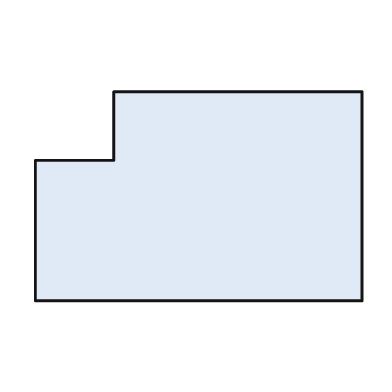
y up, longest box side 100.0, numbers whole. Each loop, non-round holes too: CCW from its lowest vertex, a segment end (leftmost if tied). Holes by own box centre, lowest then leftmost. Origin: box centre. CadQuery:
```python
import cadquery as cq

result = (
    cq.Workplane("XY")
    .moveTo(-50.0, -32.0)
    .lineTo(50.0, -32.0)
    .lineTo(50.0, 32.0)
    .lineTo(-26.0, 32.0)
    .lineTo(-26.0, 11.0)
    .lineTo(-50.0, 11.0)
    .close()
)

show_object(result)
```